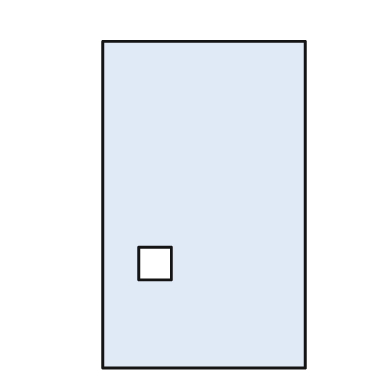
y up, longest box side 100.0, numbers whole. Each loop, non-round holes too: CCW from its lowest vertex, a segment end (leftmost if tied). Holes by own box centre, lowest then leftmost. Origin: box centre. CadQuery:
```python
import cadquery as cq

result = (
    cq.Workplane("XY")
    .moveTo(-31.0, -50.0)
    .lineTo(31.0, -50.0)
    .lineTo(31.0, 50.0)
    .lineTo(-31.0, 50.0)
    .close()
    .moveTo(-20.0, -23.0)
    .lineTo(-10.0, -23.0)
    .lineTo(-10.0, -13.0)
    .lineTo(-20.0, -13.0)
    .close()
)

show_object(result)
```